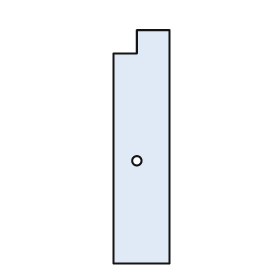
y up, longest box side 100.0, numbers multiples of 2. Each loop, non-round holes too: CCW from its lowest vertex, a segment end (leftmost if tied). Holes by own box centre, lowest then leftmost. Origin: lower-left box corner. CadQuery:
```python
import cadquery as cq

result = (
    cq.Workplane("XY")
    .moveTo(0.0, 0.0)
    .lineTo(24.0, 0.0)
    .lineTo(24.0, 100.0)
    .lineTo(10.0, 100.0)
    .lineTo(10.0, 90.0)
    .lineTo(0.0, 90.0)
    .close()
    .moveTo(10.0, 44.0)
    .circle(2.0)
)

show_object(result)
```